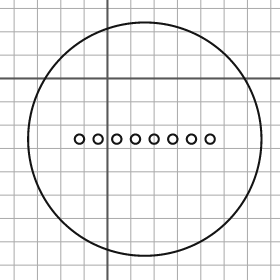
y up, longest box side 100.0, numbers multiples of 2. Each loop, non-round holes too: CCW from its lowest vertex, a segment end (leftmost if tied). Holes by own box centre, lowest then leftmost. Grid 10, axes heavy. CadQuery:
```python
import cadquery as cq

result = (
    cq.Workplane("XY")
    .moveTo(16.0, -26.0)
    .circle(50.0)
    .moveTo(-12.0, -26.0)
    .circle(2.0)
    .moveTo(-4.0, -26.0)
    .circle(2.0)
    .moveTo(4.0, -26.0)
    .circle(2.0)
    .moveTo(12.0, -26.0)
    .circle(2.0)
    .moveTo(20.0, -26.0)
    .circle(2.0)
    .moveTo(28.0, -26.0)
    .circle(2.0)
    .moveTo(36.0, -26.0)
    .circle(2.0)
    .moveTo(44.0, -26.0)
    .circle(2.0)
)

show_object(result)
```